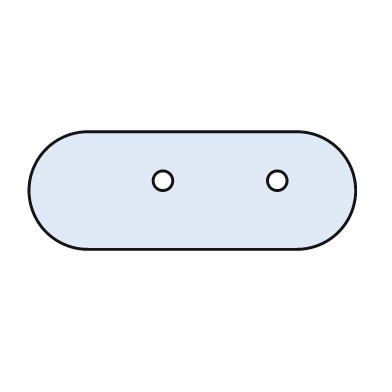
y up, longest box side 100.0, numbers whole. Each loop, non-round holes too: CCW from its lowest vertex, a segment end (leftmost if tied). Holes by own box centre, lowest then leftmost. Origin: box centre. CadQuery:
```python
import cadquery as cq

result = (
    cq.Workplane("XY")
    .moveTo(-32.0, -18.0)
    .lineTo(32.0, -18.0)
    .threePointArc((50.0, 0.0), (32.0, 18.0))
    .lineTo(-32.0, 18.0)
    .threePointArc((-50.0, 0.0), (-32.0, -18.0))
    .close()
    .moveTo(-9.0, 3.0)
    .circle(3.0)
    .moveTo(26.0, 3.0)
    .circle(3.0)
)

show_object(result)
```